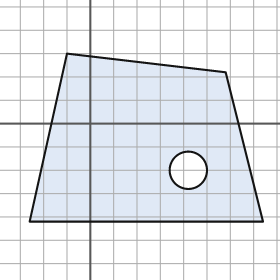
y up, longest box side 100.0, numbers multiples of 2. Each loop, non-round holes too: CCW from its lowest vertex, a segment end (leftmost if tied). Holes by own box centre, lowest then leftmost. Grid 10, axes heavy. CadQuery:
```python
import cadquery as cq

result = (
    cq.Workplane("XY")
    .moveTo(-26.0, -42.0)
    .lineTo(74.0, -42.0)
    .lineTo(58.0, 22.0)
    .lineTo(-10.0, 30.0)
    .close()
    .moveTo(42.0, -20.0)
    .circle(8.0)
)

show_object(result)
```